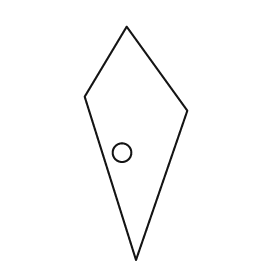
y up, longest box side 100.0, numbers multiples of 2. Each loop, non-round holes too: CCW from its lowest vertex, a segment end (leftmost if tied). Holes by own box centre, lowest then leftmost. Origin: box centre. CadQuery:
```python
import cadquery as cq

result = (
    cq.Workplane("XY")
    .moveTo(0.0, -50.0)
    .lineTo(22.0, 14.0)
    .lineTo(-4.0, 50.0)
    .lineTo(-22.0, 20.0)
    .close()
    .moveTo(-6.0, -4.0)
    .circle(4.0)
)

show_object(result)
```